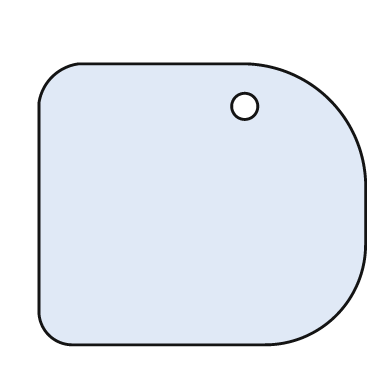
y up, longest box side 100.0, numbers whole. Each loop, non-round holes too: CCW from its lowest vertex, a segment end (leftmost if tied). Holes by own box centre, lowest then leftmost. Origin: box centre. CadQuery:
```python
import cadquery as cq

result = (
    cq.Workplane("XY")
    .moveTo(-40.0, -43.0)
    .lineTo(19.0, -43.0)
    .threePointArc((41.0, -34.0), (50.0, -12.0))
    .lineTo(50.0, 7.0)
    .threePointArc((39.0, 32.0), (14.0, 43.0))
    .lineTo(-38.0, 43.0)
    .threePointArc((-46.0, 39.0), (-50.0, 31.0))
    .lineTo(-50.0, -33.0)
    .threePointArc((-47.0, -40.0), (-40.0, -43.0))
    .close()
    .moveTo(13.0, 30.0)
    .circle(4.0)
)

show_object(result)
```